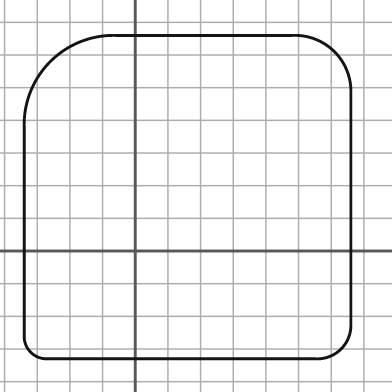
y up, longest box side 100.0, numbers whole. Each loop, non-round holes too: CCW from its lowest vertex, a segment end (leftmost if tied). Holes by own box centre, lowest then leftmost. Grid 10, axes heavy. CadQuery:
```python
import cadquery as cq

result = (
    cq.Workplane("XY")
    .moveTo(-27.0, -33.0)
    .lineTo(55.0, -33.0)
    .threePointArc((63.0, -30.0), (66.0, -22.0))
    .lineTo(66.0, 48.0)
    .threePointArc((61.0, 61.0), (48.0, 66.0))
    .lineTo(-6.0, 66.0)
    .threePointArc((-26.0, 58.0), (-34.0, 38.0))
    .lineTo(-34.0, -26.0)
    .threePointArc((-32.0, -31.0), (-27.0, -33.0))
    .close()
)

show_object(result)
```